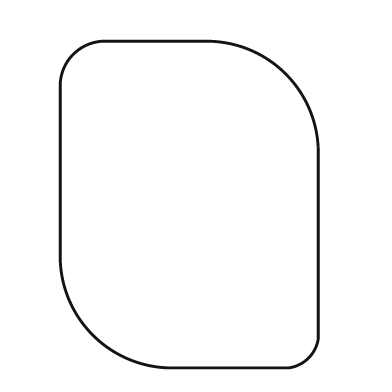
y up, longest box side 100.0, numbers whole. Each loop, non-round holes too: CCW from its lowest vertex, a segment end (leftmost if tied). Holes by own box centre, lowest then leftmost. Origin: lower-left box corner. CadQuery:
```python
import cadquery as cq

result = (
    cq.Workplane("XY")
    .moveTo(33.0, 0.0)
    .lineTo(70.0, 0.0)
    .threePointArc((76.0, 3.0), (79.0, 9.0))
    .lineTo(79.0, 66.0)
    .threePointArc((69.0, 90.0), (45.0, 100.0))
    .lineTo(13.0, 100.0)
    .threePointArc((4.0, 96.0), (0.0, 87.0))
    .lineTo(0.0, 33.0)
    .threePointArc((10.0, 10.0), (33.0, 0.0))
    .close()
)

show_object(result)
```